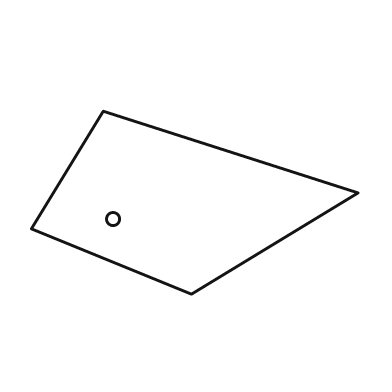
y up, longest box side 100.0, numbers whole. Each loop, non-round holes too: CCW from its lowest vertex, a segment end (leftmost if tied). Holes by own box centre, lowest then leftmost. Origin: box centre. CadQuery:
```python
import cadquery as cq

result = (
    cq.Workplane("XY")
    .moveTo(-1.0, -28.0)
    .lineTo(50.0, 3.0)
    .lineTo(-28.0, 28.0)
    .lineTo(-50.0, -8.0)
    .close()
    .moveTo(-25.0, -5.0)
    .circle(2.0)
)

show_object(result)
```